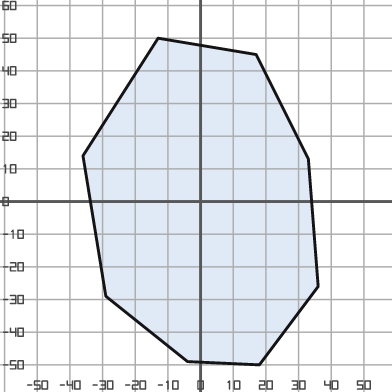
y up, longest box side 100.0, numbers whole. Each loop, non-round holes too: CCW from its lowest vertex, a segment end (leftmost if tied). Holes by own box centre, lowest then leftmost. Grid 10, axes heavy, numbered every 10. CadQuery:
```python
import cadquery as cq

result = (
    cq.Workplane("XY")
    .moveTo(18.0, -50.0)
    .lineTo(36.0, -26.0)
    .lineTo(33.0, 13.0)
    .lineTo(17.0, 45.0)
    .lineTo(-13.0, 50.0)
    .lineTo(-36.0, 14.0)
    .lineTo(-29.0, -29.0)
    .lineTo(-4.0, -49.0)
    .close()
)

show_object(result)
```